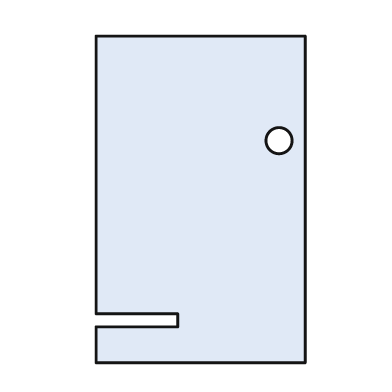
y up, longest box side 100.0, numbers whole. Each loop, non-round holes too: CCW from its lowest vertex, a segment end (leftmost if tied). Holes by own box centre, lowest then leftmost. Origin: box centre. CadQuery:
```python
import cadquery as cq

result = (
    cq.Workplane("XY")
    .moveTo(-32.0, -50.0)
    .lineTo(32.0, -50.0)
    .lineTo(32.0, 50.0)
    .lineTo(-32.0, 50.0)
    .lineTo(-32.0, -35.0)
    .lineTo(-7.0, -35.0)
    .lineTo(-7.0, -39.0)
    .lineTo(-32.0, -39.0)
    .close()
    .moveTo(24.0, 18.0)
    .circle(4.0)
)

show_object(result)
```